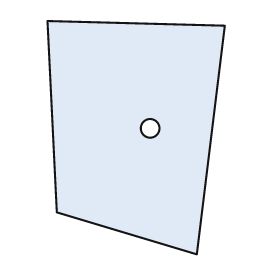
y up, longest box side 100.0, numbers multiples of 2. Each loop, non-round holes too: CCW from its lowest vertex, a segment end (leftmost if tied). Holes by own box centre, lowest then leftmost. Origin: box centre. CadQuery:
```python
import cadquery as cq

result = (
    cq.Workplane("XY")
    .moveTo(26.0, -50.0)
    .lineTo(38.0, 48.0)
    .lineTo(-38.0, 50.0)
    .lineTo(-34.0, -32.0)
    .close()
    .moveTo(6.0, 4.0)
    .circle(4.0)
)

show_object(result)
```